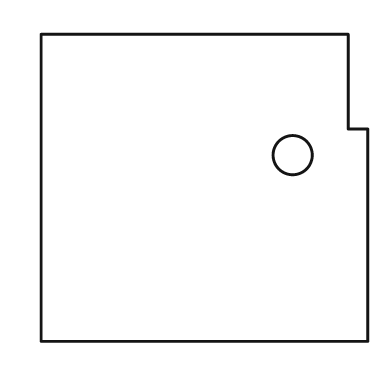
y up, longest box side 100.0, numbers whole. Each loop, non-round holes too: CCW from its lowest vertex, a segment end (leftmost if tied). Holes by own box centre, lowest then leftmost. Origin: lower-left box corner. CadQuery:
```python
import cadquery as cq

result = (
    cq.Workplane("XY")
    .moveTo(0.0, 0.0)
    .lineTo(100.0, 0.0)
    .lineTo(100.0, 65.0)
    .lineTo(94.0, 65.0)
    .lineTo(94.0, 94.0)
    .lineTo(0.0, 94.0)
    .close()
    .moveTo(77.0, 57.0)
    .circle(6.0)
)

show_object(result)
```